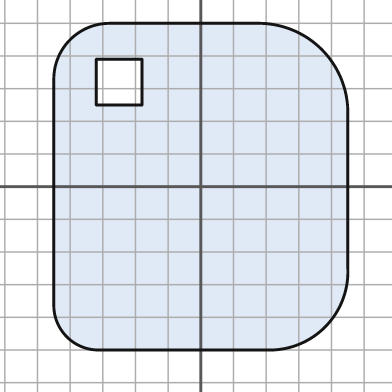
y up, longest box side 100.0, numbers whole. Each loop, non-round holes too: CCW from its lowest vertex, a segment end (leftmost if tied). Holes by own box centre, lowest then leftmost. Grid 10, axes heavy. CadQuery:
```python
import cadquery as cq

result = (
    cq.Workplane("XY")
    .moveTo(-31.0, -50.0)
    .lineTo(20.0, -50.0)
    .threePointArc((38.0, -43.0), (45.0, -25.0))
    .lineTo(45.0, 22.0)
    .threePointArc((37.0, 42.0), (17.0, 50.0))
    .lineTo(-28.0, 50.0)
    .threePointArc((-40.0, 45.0), (-45.0, 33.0))
    .lineTo(-45.0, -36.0)
    .threePointArc((-41.0, -46.0), (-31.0, -50.0))
    .close()
    .moveTo(-32.0, 25.0)
    .lineTo(-18.0, 25.0)
    .lineTo(-18.0, 39.0)
    .lineTo(-32.0, 39.0)
    .close()
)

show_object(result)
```